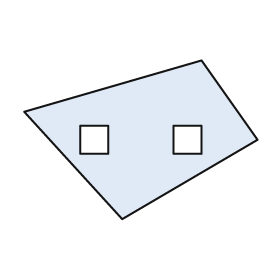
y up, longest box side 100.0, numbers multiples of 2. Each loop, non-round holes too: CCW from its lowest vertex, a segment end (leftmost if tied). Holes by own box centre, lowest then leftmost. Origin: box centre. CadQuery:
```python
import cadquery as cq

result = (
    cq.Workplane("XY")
    .moveTo(-8.0, -34.0)
    .lineTo(50.0, 0.0)
    .lineTo(26.0, 34.0)
    .lineTo(-50.0, 12.0)
    .close()
    .moveTo(-26.0, -6.0)
    .lineTo(-14.0, -6.0)
    .lineTo(-14.0, 6.0)
    .lineTo(-26.0, 6.0)
    .close()
    .moveTo(14.0, -6.0)
    .lineTo(26.0, -6.0)
    .lineTo(26.0, 6.0)
    .lineTo(14.0, 6.0)
    .close()
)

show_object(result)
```